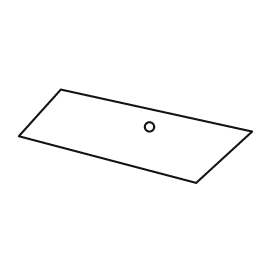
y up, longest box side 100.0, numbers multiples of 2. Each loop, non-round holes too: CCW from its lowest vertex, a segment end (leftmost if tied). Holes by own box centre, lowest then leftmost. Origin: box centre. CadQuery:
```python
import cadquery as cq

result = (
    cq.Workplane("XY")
    .moveTo(26.0, -20.0)
    .lineTo(50.0, 2.0)
    .lineTo(-32.0, 20.0)
    .lineTo(-50.0, 0.0)
    .close()
    .moveTo(6.0, 4.0)
    .circle(2.0)
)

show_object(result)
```